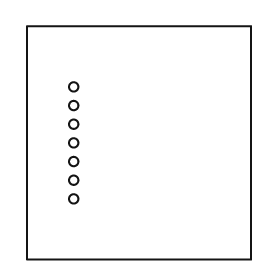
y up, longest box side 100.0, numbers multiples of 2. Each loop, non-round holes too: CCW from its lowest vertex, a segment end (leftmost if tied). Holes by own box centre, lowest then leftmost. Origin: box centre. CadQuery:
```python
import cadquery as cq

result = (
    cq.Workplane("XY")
    .moveTo(-48.0, -50.0)
    .lineTo(48.0, -50.0)
    .lineTo(48.0, 50.0)
    .lineTo(-48.0, 50.0)
    .close()
    .moveTo(-28.0, -24.0)
    .circle(2.0)
    .moveTo(-28.0, -16.0)
    .circle(2.0)
    .moveTo(-28.0, -8.0)
    .circle(2.0)
    .moveTo(-28.0, 0.0)
    .circle(2.0)
    .moveTo(-28.0, 8.0)
    .circle(2.0)
    .moveTo(-28.0, 16.0)
    .circle(2.0)
    .moveTo(-28.0, 24.0)
    .circle(2.0)
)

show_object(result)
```